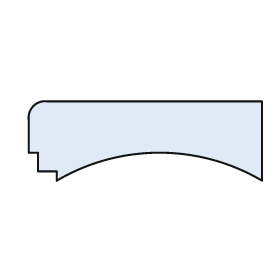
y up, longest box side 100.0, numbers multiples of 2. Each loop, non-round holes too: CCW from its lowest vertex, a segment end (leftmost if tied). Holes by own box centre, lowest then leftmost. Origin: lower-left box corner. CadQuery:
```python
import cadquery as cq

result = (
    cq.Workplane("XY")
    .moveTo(12.0, 0.0)
    .threePointArc((56.0, 12.0), (100.0, 0.0))
    .lineTo(100.0, 34.0)
    .lineTo(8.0, 34.0)
    .threePointArc((2.0, 32.0), (0.0, 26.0))
    .lineTo(0.0, 12.0)
    .lineTo(4.0, 12.0)
    .lineTo(4.0, 4.0)
    .lineTo(12.0, 4.0)
    .close()
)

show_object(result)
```